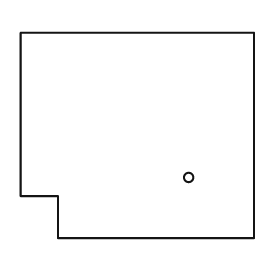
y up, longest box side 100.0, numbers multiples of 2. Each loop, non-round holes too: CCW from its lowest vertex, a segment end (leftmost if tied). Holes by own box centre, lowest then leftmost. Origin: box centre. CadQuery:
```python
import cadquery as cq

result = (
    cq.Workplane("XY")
    .moveTo(-34.0, -44.0)
    .lineTo(50.0, -44.0)
    .lineTo(50.0, 44.0)
    .lineTo(-50.0, 44.0)
    .lineTo(-50.0, -26.0)
    .lineTo(-34.0, -26.0)
    .close()
    .moveTo(22.0, -18.0)
    .circle(2.0)
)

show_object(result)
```